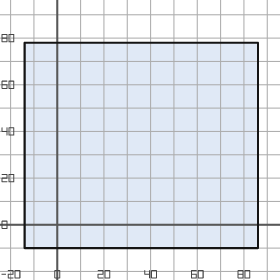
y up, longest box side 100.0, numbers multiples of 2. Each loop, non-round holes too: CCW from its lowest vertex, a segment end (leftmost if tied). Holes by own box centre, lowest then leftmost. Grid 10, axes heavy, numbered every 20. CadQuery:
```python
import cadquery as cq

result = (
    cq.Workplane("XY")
    .moveTo(-14.0, -10.0)
    .lineTo(86.0, -10.0)
    .lineTo(86.0, 78.0)
    .lineTo(-14.0, 78.0)
    .close()
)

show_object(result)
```